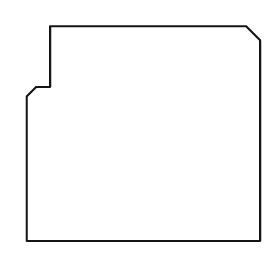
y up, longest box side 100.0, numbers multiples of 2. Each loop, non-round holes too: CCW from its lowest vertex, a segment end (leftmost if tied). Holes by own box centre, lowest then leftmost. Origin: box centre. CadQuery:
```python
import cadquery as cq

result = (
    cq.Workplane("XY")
    .moveTo(-50.0, -46.0)
    .lineTo(50.0, -46.0)
    .lineTo(50.0, 40.0)
    .lineTo(44.0, 46.0)
    .lineTo(-40.0, 46.0)
    .lineTo(-40.0, 20.0)
    .lineTo(-46.0, 20.0)
    .lineTo(-50.0, 16.0)
    .close()
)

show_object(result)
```